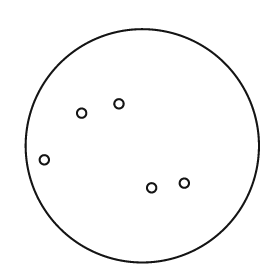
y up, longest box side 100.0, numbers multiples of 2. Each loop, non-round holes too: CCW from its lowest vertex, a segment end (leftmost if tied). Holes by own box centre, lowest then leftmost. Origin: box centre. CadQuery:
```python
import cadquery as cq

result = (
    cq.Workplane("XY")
    .moveTo(0.0, 0.0)
    .circle(50.0)
    .moveTo(4.0, -18.0)
    .circle(2.0)
    .moveTo(18.0, -16.0)
    .circle(2.0)
    .moveTo(-42.0, -6.0)
    .circle(2.0)
    .moveTo(-26.0, 14.0)
    .circle(2.0)
    .moveTo(-10.0, 18.0)
    .circle(2.0)
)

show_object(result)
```